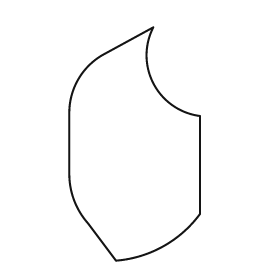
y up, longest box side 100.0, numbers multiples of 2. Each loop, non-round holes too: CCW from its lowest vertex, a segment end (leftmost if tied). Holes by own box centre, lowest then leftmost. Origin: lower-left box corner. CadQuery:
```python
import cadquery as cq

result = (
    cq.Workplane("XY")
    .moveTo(20.0, 0.0)
    .threePointArc((40.0, 6.0), (56.0, 20.0))
    .lineTo(56.0, 62.0)
    .threePointArc((36.0, 76.0), (36.0, 100.0))
    .lineTo(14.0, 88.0)
    .threePointArc((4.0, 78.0), (0.0, 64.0))
    .lineTo(0.0, 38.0)
    .threePointArc((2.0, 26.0), (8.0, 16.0))
    .close()
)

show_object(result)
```